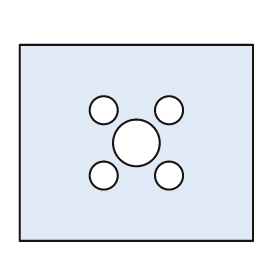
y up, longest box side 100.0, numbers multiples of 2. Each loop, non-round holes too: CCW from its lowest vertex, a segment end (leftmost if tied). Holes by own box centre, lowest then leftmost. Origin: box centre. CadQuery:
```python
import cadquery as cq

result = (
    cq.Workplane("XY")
    .moveTo(-50.0, -42.0)
    .lineTo(50.0, -42.0)
    .lineTo(50.0, 42.0)
    .lineTo(-50.0, 42.0)
    .close()
    .moveTo(-14.0, -14.0)
    .circle(6.0)
    .moveTo(14.0, -14.0)
    .circle(6.0)
    .moveTo(0.0, 0.0)
    .circle(10.0)
    .moveTo(-14.0, 14.0)
    .circle(6.0)
    .moveTo(14.0, 14.0)
    .circle(6.0)
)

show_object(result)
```